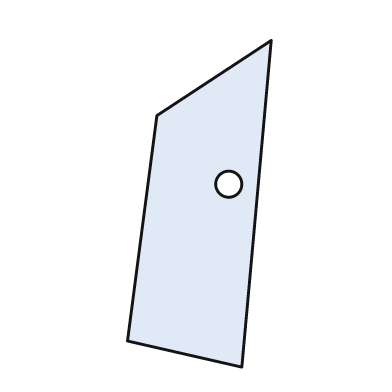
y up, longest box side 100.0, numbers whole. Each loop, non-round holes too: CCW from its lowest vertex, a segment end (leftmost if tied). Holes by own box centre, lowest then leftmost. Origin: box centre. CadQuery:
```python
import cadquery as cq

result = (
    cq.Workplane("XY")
    .moveTo(13.0, -50.0)
    .lineTo(22.0, 50.0)
    .lineTo(-13.0, 27.0)
    .lineTo(-22.0, -42.0)
    .close()
    .moveTo(9.0, 6.0)
    .circle(4.0)
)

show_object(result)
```